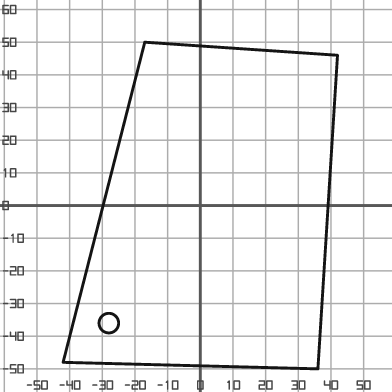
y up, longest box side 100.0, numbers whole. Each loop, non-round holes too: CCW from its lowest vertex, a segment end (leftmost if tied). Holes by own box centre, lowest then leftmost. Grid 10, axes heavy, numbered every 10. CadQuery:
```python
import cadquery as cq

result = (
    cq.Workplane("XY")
    .moveTo(36.0, -50.0)
    .lineTo(42.0, 46.0)
    .lineTo(-17.0, 50.0)
    .lineTo(-42.0, -48.0)
    .close()
    .moveTo(-28.0, -36.0)
    .circle(3.0)
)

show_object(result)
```